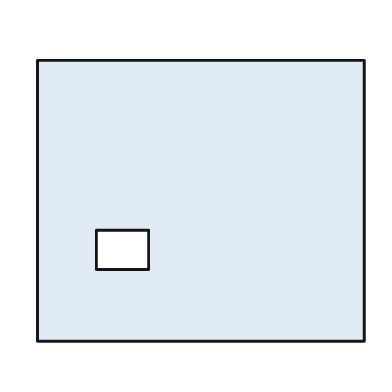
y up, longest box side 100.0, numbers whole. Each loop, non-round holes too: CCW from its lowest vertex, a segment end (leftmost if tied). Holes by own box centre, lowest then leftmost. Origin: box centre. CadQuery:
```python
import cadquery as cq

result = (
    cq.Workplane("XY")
    .moveTo(-50.0, -43.0)
    .lineTo(50.0, -43.0)
    .lineTo(50.0, 43.0)
    .lineTo(-50.0, 43.0)
    .close()
    .moveTo(-32.0, -21.0)
    .lineTo(-16.0, -21.0)
    .lineTo(-16.0, -9.0)
    .lineTo(-32.0, -9.0)
    .close()
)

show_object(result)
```